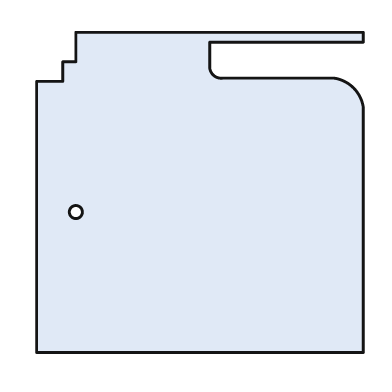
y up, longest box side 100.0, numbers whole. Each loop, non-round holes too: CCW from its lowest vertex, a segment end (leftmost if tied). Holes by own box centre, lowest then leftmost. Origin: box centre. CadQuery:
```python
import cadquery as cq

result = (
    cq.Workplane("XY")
    .moveTo(-50.0, -49.0)
    .lineTo(50.0, -49.0)
    .lineTo(50.0, 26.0)
    .threePointArc((47.0, 32.0), (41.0, 35.0))
    .lineTo(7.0, 35.0)
    .threePointArc((4.0, 36.0), (3.0, 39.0))
    .lineTo(3.0, 46.0)
    .lineTo(50.0, 46.0)
    .lineTo(50.0, 49.0)
    .lineTo(-38.0, 49.0)
    .lineTo(-38.0, 40.0)
    .lineTo(-42.0, 40.0)
    .lineTo(-42.0, 34.0)
    .lineTo(-50.0, 34.0)
    .close()
    .moveTo(-38.0, -6.0)
    .circle(2.0)
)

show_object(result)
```